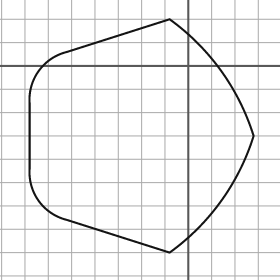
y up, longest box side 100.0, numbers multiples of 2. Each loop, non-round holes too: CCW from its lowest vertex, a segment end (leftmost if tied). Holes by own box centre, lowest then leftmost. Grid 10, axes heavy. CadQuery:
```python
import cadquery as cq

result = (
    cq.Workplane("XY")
    .moveTo(-8.0, -80.0)
    .threePointArc((14.0, -58.0), (28.0, -30.0))
    .threePointArc((14.0, -2.0), (-8.0, 20.0))
    .lineTo(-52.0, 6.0)
    .threePointArc((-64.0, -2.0), (-68.0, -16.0))
    .lineTo(-68.0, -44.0)
    .threePointArc((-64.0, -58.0), (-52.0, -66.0))
    .close()
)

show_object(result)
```